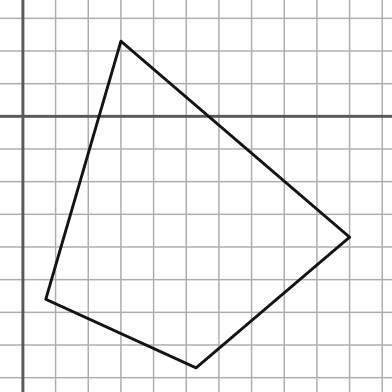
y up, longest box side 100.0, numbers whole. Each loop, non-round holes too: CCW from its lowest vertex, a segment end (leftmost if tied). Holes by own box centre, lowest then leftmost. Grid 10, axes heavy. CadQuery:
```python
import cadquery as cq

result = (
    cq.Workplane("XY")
    .moveTo(53.0, -77.0)
    .lineTo(100.0, -37.0)
    .lineTo(30.0, 23.0)
    .lineTo(7.0, -56.0)
    .close()
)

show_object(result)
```